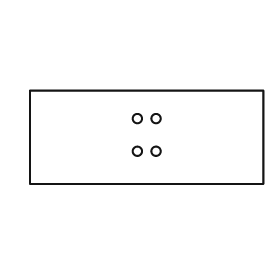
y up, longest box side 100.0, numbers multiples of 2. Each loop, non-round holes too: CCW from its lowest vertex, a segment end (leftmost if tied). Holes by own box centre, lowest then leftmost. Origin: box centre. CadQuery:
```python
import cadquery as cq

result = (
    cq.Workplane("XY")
    .moveTo(-50.0, -20.0)
    .lineTo(50.0, -20.0)
    .lineTo(50.0, 20.0)
    .lineTo(-50.0, 20.0)
    .close()
    .moveTo(-4.0, -6.0)
    .circle(2.0)
    .moveTo(4.0, -6.0)
    .circle(2.0)
    .moveTo(-4.0, 8.0)
    .circle(2.0)
    .moveTo(4.0, 8.0)
    .circle(2.0)
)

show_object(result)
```